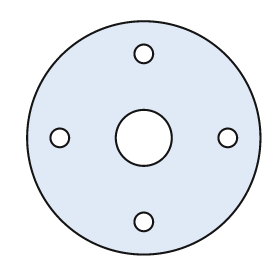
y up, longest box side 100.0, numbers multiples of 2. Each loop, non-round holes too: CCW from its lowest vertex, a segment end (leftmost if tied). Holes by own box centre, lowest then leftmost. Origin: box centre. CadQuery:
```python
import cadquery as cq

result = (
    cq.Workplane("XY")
    .moveTo(0.0, 0.0)
    .circle(50.0)
    .moveTo(0.0, -36.0)
    .circle(4.0)
    .moveTo(-36.0, 0.0)
    .circle(4.0)
    .moveTo(0.0, 0.0)
    .circle(12.0)
    .moveTo(36.0, 0.0)
    .circle(4.0)
    .moveTo(0.0, 36.0)
    .circle(4.0)
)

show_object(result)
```